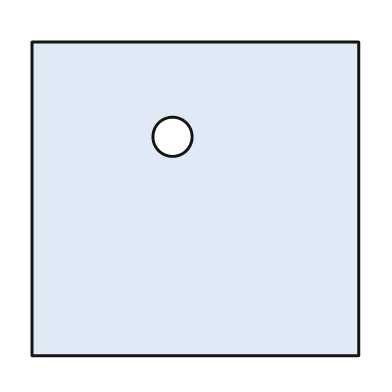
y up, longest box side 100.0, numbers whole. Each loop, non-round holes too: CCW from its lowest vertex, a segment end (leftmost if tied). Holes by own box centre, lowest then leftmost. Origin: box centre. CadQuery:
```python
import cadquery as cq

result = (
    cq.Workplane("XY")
    .moveTo(-50.0, -48.0)
    .lineTo(50.0, -48.0)
    .lineTo(50.0, 48.0)
    .lineTo(-50.0, 48.0)
    .close()
    .moveTo(-7.0, 19.0)
    .circle(6.0)
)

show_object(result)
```